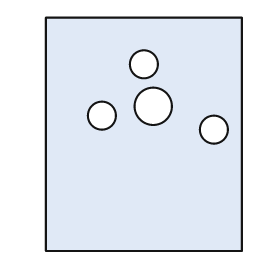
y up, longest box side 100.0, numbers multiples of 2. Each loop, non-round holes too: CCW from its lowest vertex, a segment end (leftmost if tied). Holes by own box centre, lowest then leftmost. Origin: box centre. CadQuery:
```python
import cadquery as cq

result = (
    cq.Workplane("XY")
    .moveTo(-42.0, -50.0)
    .lineTo(42.0, -50.0)
    .lineTo(42.0, 50.0)
    .lineTo(-42.0, 50.0)
    .close()
    .moveTo(30.0, 2.0)
    .circle(6.0)
    .moveTo(-18.0, 8.0)
    .circle(6.0)
    .moveTo(4.0, 12.0)
    .circle(8.0)
    .moveTo(0.0, 30.0)
    .circle(6.0)
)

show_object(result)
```